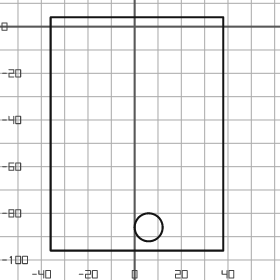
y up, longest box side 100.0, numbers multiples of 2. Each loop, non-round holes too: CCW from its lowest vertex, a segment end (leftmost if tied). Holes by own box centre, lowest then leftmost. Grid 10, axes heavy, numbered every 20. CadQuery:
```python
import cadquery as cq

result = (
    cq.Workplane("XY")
    .moveTo(-36.0, -96.0)
    .lineTo(38.0, -96.0)
    .lineTo(38.0, 4.0)
    .lineTo(-36.0, 4.0)
    .close()
    .moveTo(6.0, -86.0)
    .circle(6.0)
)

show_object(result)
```